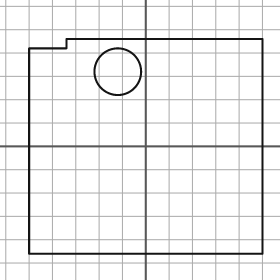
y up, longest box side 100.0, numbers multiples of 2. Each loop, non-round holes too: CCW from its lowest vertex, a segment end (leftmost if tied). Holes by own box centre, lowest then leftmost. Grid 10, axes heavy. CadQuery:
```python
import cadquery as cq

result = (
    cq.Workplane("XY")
    .moveTo(-50.0, -46.0)
    .lineTo(50.0, -46.0)
    .lineTo(50.0, 46.0)
    .lineTo(-34.0, 46.0)
    .lineTo(-34.0, 42.0)
    .lineTo(-50.0, 42.0)
    .close()
    .moveTo(-12.0, 32.0)
    .circle(10.0)
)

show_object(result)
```